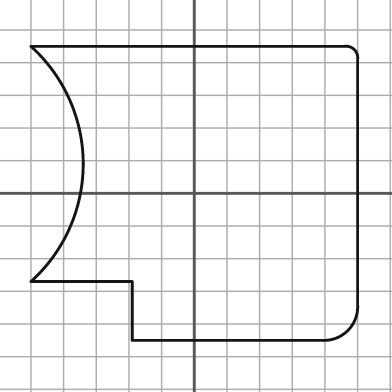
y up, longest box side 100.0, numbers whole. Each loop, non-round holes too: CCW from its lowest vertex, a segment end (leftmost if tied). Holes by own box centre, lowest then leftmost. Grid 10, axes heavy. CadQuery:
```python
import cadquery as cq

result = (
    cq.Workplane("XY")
    .moveTo(-19.0, -45.0)
    .lineTo(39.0, -45.0)
    .threePointArc((47.0, -42.0), (50.0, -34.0))
    .lineTo(50.0, 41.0)
    .threePointArc((49.0, 44.0), (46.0, 45.0))
    .lineTo(-50.0, 45.0)
    .threePointArc((-34.0, 9.0), (-50.0, -27.0))
    .lineTo(-19.0, -27.0)
    .close()
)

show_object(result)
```